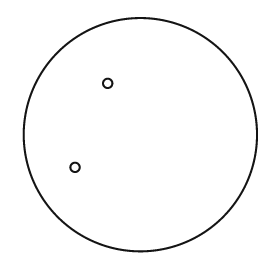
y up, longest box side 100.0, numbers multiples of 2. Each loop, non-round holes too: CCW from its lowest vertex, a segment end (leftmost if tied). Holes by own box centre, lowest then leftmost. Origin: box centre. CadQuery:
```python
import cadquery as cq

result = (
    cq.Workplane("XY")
    .moveTo(0.0, 0.0)
    .circle(50.0)
    .moveTo(-28.0, -14.0)
    .circle(2.0)
    .moveTo(-14.0, 22.0)
    .circle(2.0)
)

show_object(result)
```